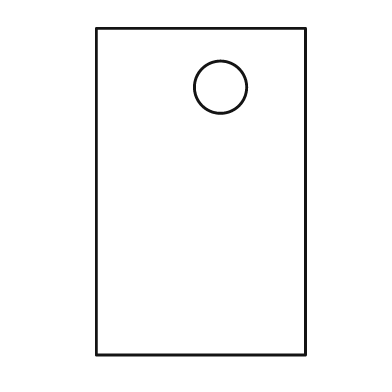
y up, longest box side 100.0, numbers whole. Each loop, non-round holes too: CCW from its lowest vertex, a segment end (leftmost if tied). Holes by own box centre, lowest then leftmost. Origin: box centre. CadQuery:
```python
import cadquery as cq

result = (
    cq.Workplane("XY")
    .moveTo(-32.0, -50.0)
    .lineTo(32.0, -50.0)
    .lineTo(32.0, 50.0)
    .lineTo(-32.0, 50.0)
    .close()
    .moveTo(6.0, 32.0)
    .circle(8.0)
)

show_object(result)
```